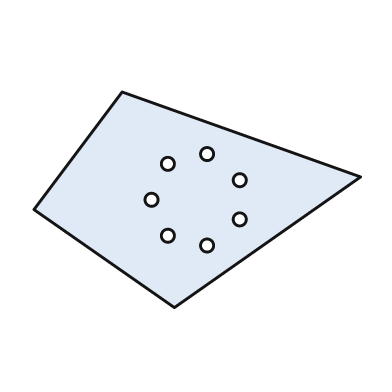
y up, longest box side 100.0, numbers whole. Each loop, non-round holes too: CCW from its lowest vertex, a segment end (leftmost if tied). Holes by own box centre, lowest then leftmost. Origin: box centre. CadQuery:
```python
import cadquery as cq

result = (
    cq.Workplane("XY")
    .moveTo(-7.0, -33.0)
    .lineTo(50.0, 7.0)
    .lineTo(-23.0, 33.0)
    .lineTo(-50.0, -3.0)
    .close()
    .moveTo(3.0, -14.0)
    .circle(2.0)
    .moveTo(-9.0, -11.0)
    .circle(2.0)
    .moveTo(13.0, -6.0)
    .circle(2.0)
    .moveTo(-14.0, 0.0)
    .circle(2.0)
    .moveTo(13.0, 6.0)
    .circle(2.0)
    .moveTo(-9.0, 11.0)
    .circle(2.0)
    .moveTo(3.0, 14.0)
    .circle(2.0)
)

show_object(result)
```